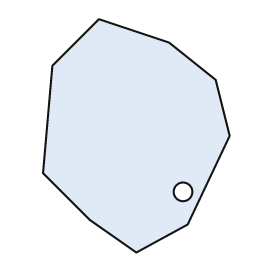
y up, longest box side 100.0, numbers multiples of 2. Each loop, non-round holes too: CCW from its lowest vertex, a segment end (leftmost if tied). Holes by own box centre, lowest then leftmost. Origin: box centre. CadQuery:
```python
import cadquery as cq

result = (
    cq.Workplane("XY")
    .moveTo(0.0, -50.0)
    .lineTo(22.0, -38.0)
    .lineTo(40.0, 0.0)
    .lineTo(34.0, 24.0)
    .lineTo(14.0, 40.0)
    .lineTo(-16.0, 50.0)
    .lineTo(-36.0, 30.0)
    .lineTo(-40.0, -16.0)
    .lineTo(-20.0, -36.0)
    .close()
    .moveTo(20.0, -24.0)
    .circle(4.0)
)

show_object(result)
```